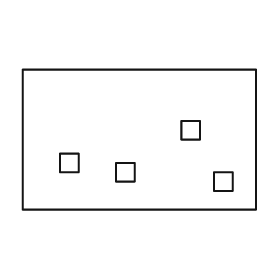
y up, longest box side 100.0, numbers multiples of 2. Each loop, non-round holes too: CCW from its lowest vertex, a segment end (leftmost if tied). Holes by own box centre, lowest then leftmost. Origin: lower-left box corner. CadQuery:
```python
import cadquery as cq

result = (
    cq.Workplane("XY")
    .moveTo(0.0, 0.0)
    .lineTo(100.0, 0.0)
    .lineTo(100.0, 60.0)
    .lineTo(0.0, 60.0)
    .close()
    .moveTo(82.0, 8.0)
    .lineTo(90.0, 8.0)
    .lineTo(90.0, 16.0)
    .lineTo(82.0, 16.0)
    .close()
    .moveTo(40.0, 12.0)
    .lineTo(48.0, 12.0)
    .lineTo(48.0, 20.0)
    .lineTo(40.0, 20.0)
    .close()
    .moveTo(16.0, 16.0)
    .lineTo(24.0, 16.0)
    .lineTo(24.0, 24.0)
    .lineTo(16.0, 24.0)
    .close()
    .moveTo(68.0, 30.0)
    .lineTo(76.0, 30.0)
    .lineTo(76.0, 38.0)
    .lineTo(68.0, 38.0)
    .close()
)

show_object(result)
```